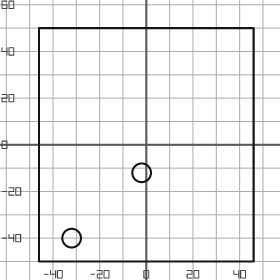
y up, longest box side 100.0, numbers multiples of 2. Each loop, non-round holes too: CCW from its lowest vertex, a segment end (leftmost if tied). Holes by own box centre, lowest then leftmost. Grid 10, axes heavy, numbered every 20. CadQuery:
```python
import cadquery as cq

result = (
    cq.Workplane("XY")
    .moveTo(-46.0, -50.0)
    .lineTo(46.0, -50.0)
    .lineTo(46.0, 50.0)
    .lineTo(-46.0, 50.0)
    .close()
    .moveTo(-32.0, -40.0)
    .circle(4.0)
    .moveTo(-2.0, -12.0)
    .circle(4.0)
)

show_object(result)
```